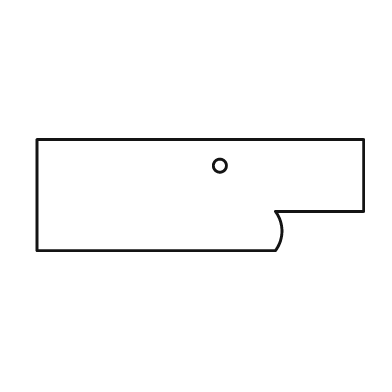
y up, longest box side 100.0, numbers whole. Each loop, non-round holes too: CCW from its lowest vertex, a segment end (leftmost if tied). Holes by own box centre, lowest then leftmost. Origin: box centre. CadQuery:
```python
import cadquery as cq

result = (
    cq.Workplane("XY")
    .moveTo(-50.0, -17.0)
    .lineTo(23.0, -17.0)
    .threePointArc((25.0, -11.0), (23.0, -5.0))
    .lineTo(50.0, -5.0)
    .lineTo(50.0, 17.0)
    .lineTo(-50.0, 17.0)
    .close()
    .moveTo(6.0, 9.0)
    .circle(2.0)
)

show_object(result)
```